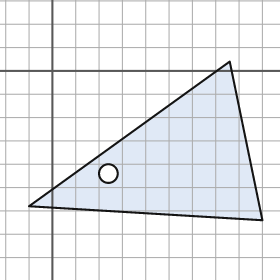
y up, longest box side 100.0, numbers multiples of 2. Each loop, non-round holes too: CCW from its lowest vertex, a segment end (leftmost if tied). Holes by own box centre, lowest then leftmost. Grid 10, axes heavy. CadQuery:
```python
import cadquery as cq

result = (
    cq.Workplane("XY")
    .moveTo(90.0, -64.0)
    .lineTo(76.0, 4.0)
    .lineTo(-10.0, -58.0)
    .close()
    .moveTo(24.0, -44.0)
    .circle(4.0)
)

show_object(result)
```